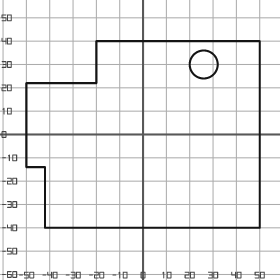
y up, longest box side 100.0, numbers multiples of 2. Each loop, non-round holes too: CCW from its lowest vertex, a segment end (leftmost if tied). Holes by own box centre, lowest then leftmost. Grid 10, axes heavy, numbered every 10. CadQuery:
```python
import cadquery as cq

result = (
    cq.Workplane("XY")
    .moveTo(-42.0, -40.0)
    .lineTo(50.0, -40.0)
    .lineTo(50.0, 40.0)
    .lineTo(-20.0, 40.0)
    .lineTo(-20.0, 22.0)
    .lineTo(-50.0, 22.0)
    .lineTo(-50.0, -14.0)
    .lineTo(-42.0, -14.0)
    .close()
    .moveTo(26.0, 30.0)
    .circle(6.0)
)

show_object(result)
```